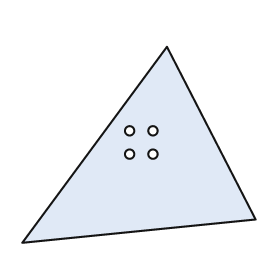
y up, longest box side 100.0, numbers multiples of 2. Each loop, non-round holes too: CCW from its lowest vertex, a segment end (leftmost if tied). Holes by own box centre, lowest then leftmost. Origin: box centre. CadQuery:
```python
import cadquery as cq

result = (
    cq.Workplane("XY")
    .moveTo(-50.0, -42.0)
    .lineTo(50.0, -32.0)
    .lineTo(12.0, 42.0)
    .close()
    .moveTo(-4.0, -4.0)
    .circle(2.0)
    .moveTo(6.0, -4.0)
    .circle(2.0)
    .moveTo(-4.0, 6.0)
    .circle(2.0)
    .moveTo(6.0, 6.0)
    .circle(2.0)
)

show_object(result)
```